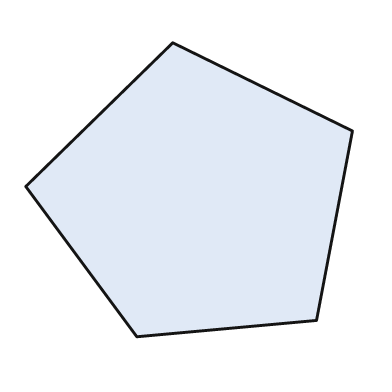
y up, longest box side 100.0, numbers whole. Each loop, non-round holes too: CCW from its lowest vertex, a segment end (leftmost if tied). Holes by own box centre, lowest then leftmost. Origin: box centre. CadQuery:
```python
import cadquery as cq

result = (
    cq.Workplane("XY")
    .moveTo(-16.0, -45.0)
    .lineTo(39.0, -40.0)
    .lineTo(50.0, 18.0)
    .lineTo(-5.0, 45.0)
    .lineTo(-50.0, 1.0)
    .close()
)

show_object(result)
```